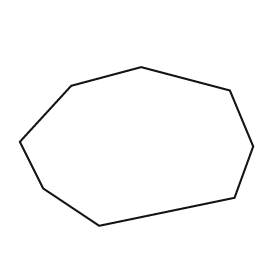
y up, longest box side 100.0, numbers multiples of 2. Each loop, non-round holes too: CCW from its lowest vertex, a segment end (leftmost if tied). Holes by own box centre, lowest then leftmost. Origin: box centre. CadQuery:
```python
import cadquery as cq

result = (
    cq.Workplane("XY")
    .moveTo(-16.0, -34.0)
    .lineTo(42.0, -22.0)
    .lineTo(50.0, 0.0)
    .lineTo(40.0, 24.0)
    .lineTo(2.0, 34.0)
    .lineTo(-28.0, 26.0)
    .lineTo(-50.0, 2.0)
    .lineTo(-40.0, -18.0)
    .close()
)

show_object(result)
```